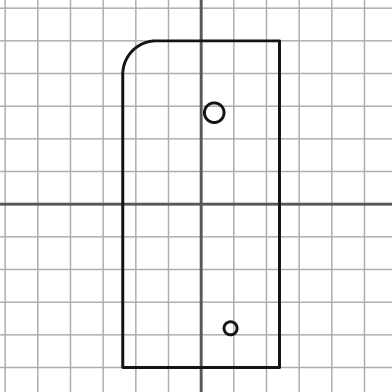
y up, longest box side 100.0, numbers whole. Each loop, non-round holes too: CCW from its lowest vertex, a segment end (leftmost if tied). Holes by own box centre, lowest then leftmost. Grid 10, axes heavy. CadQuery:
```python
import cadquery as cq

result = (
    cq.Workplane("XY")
    .moveTo(-24.0, -50.0)
    .lineTo(24.0, -50.0)
    .lineTo(24.0, 50.0)
    .lineTo(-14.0, 50.0)
    .threePointArc((-21.0, 47.0), (-24.0, 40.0))
    .close()
    .moveTo(9.0, -38.0)
    .circle(2.0)
    .moveTo(4.0, 28.0)
    .circle(3.0)
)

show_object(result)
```